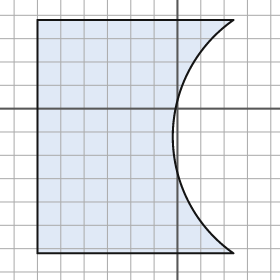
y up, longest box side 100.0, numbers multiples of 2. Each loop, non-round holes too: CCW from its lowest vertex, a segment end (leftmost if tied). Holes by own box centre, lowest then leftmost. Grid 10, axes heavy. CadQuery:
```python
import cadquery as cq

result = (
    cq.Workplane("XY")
    .moveTo(-60.0, -62.0)
    .lineTo(24.0, -62.0)
    .threePointArc((-2.0, -12.0), (24.0, 38.0))
    .lineTo(-60.0, 38.0)
    .close()
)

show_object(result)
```